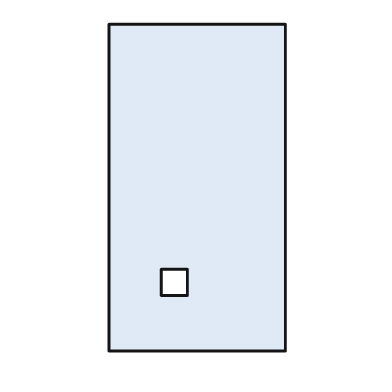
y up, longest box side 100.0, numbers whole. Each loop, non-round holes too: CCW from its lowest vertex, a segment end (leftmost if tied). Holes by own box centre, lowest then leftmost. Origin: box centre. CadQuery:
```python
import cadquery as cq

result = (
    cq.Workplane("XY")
    .moveTo(-27.0, -50.0)
    .lineTo(27.0, -50.0)
    .lineTo(27.0, 50.0)
    .lineTo(-27.0, 50.0)
    .close()
    .moveTo(-11.0, -33.0)
    .lineTo(-3.0, -33.0)
    .lineTo(-3.0, -25.0)
    .lineTo(-11.0, -25.0)
    .close()
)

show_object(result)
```